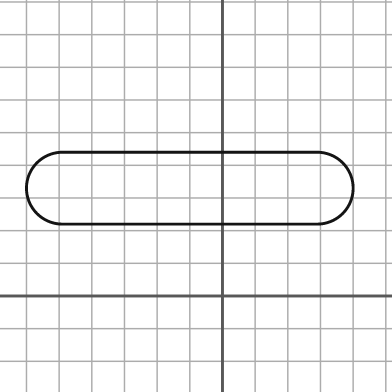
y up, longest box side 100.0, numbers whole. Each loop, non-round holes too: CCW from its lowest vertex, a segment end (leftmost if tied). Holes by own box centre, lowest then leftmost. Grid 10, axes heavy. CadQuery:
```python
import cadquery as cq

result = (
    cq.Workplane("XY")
    .moveTo(-49.0, 22.0)
    .lineTo(29.0, 22.0)
    .threePointArc((40.0, 33.0), (29.0, 44.0))
    .lineTo(-49.0, 44.0)
    .threePointArc((-60.0, 33.0), (-49.0, 22.0))
    .close()
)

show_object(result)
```